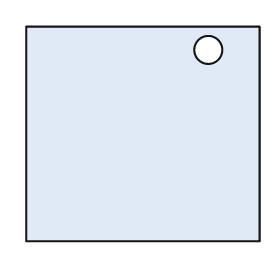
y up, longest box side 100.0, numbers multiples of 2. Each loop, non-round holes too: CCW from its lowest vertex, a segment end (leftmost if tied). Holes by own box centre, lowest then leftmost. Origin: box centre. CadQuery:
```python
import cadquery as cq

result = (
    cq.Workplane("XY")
    .moveTo(-50.0, -46.0)
    .lineTo(50.0, -46.0)
    .lineTo(50.0, 46.0)
    .lineTo(-50.0, 46.0)
    .close()
    .moveTo(28.0, 36.0)
    .circle(6.0)
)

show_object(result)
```